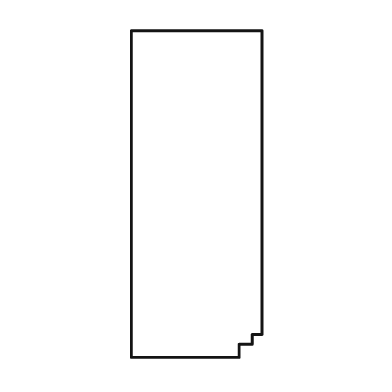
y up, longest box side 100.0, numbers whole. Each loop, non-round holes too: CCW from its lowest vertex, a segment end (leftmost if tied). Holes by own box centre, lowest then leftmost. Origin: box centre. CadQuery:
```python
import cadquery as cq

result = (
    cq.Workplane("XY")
    .moveTo(-20.0, -50.0)
    .lineTo(13.0, -50.0)
    .lineTo(13.0, -46.0)
    .lineTo(17.0, -46.0)
    .lineTo(17.0, -43.0)
    .lineTo(20.0, -43.0)
    .lineTo(20.0, 50.0)
    .lineTo(-20.0, 50.0)
    .close()
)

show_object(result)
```